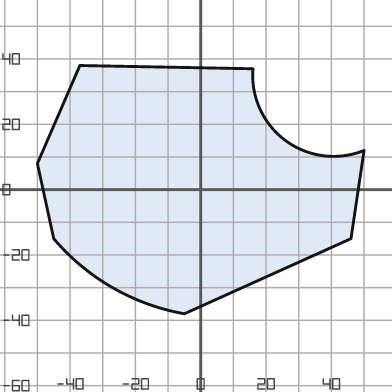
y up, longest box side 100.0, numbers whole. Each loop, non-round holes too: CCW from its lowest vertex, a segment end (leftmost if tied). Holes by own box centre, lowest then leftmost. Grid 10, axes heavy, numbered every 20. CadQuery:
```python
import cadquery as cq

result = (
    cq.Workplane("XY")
    .moveTo(-5.0, -38.0)
    .lineTo(46.0, -15.0)
    .lineTo(50.0, 12.0)
    .threePointArc((26.0, 15.0), (16.0, 37.0))
    .lineTo(-37.0, 38.0)
    .lineTo(-50.0, 8.0)
    .lineTo(-45.0, -15.0)
    .threePointArc((-27.0, -30.0), (-5.0, -38.0))
    .close()
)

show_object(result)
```